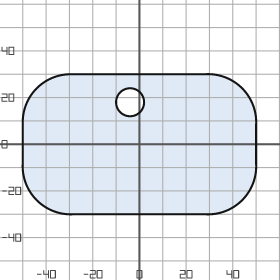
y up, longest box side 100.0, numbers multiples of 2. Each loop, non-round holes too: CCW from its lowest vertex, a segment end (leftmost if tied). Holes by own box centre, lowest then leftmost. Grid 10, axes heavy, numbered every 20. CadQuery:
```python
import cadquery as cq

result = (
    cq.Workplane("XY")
    .moveTo(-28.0, -30.0)
    .lineTo(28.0, -30.0)
    .threePointArc((44.0, -24.0), (50.0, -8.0))
    .lineTo(50.0, 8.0)
    .threePointArc((44.0, 24.0), (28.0, 30.0))
    .lineTo(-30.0, 30.0)
    .threePointArc((-44.0, 24.0), (-50.0, 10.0))
    .lineTo(-50.0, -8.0)
    .threePointArc((-44.0, -24.0), (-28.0, -30.0))
    .close()
    .moveTo(-4.0, 18.0)
    .circle(6.0)
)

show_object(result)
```